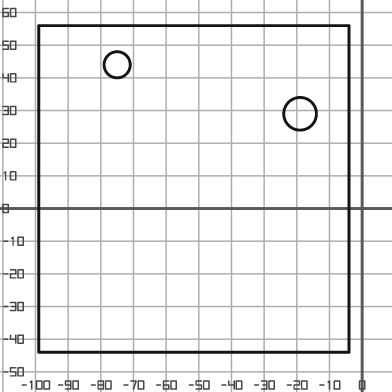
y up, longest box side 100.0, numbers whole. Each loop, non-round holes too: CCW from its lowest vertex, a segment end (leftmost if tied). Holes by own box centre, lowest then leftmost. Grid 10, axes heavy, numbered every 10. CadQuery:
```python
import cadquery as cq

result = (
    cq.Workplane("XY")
    .moveTo(-99.0, -44.0)
    .lineTo(-4.0, -44.0)
    .lineTo(-4.0, 56.0)
    .lineTo(-99.0, 56.0)
    .close()
    .moveTo(-19.0, 29.0)
    .circle(5.0)
    .moveTo(-75.0, 44.0)
    .circle(4.0)
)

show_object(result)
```